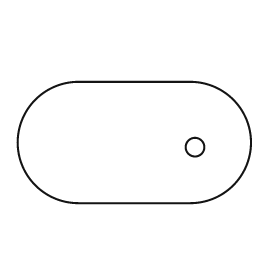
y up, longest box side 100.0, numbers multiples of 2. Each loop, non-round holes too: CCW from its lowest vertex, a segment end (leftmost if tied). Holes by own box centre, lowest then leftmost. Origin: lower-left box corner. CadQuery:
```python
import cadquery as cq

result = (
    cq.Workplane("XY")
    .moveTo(26.0, 0.0)
    .lineTo(74.0, 0.0)
    .threePointArc((100.0, 26.0), (74.0, 52.0))
    .lineTo(26.0, 52.0)
    .threePointArc((0.0, 26.0), (26.0, 0.0))
    .close()
    .moveTo(76.0, 24.0)
    .circle(4.0)
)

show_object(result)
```